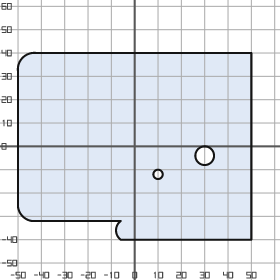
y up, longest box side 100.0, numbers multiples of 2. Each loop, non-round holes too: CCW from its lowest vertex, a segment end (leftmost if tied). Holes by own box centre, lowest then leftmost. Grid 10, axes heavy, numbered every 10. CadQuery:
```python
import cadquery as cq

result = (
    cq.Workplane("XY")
    .moveTo(-6.0, -40.0)
    .lineTo(50.0, -40.0)
    .lineTo(50.0, 40.0)
    .lineTo(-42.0, 40.0)
    .threePointArc((-48.0, 38.0), (-50.0, 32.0))
    .lineTo(-50.0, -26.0)
    .threePointArc((-48.0, -30.0), (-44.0, -32.0))
    .lineTo(-6.0, -32.0)
    .threePointArc((-8.0, -36.0), (-6.0, -40.0))
    .close()
    .moveTo(10.0, -12.0)
    .circle(2.0)
    .moveTo(30.0, -4.0)
    .circle(4.0)
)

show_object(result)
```